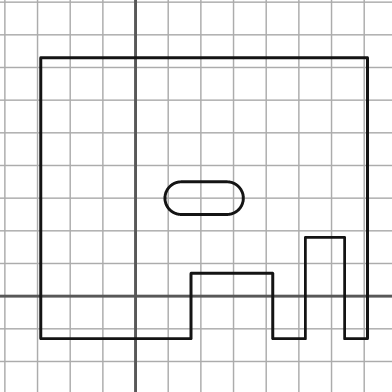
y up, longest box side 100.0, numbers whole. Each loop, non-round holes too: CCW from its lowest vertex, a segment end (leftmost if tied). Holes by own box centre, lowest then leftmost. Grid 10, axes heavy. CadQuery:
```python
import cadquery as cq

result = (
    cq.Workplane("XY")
    .moveTo(-29.0, -13.0)
    .lineTo(17.0, -13.0)
    .lineTo(17.0, 7.0)
    .lineTo(42.0, 7.0)
    .lineTo(42.0, -13.0)
    .lineTo(52.0, -13.0)
    .lineTo(52.0, 18.0)
    .lineTo(64.0, 18.0)
    .lineTo(64.0, -13.0)
    .lineTo(71.0, -13.0)
    .lineTo(71.0, 73.0)
    .lineTo(-29.0, 73.0)
    .close()
    .moveTo(14.0, 25.0)
    .lineTo(28.0, 25.0)
    .threePointArc((33.0, 30.0), (28.0, 35.0))
    .lineTo(14.0, 35.0)
    .threePointArc((9.0, 30.0), (14.0, 25.0))
    .close()
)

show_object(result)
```